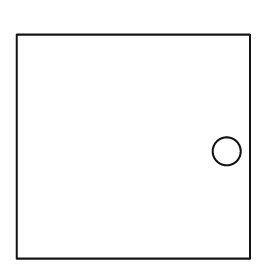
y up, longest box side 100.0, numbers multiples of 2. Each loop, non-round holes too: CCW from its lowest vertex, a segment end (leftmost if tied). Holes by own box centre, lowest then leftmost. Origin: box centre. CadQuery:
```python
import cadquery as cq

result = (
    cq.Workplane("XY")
    .moveTo(-50.0, -48.0)
    .lineTo(50.0, -48.0)
    .lineTo(50.0, 48.0)
    .lineTo(-50.0, 48.0)
    .close()
    .moveTo(40.0, -2.0)
    .circle(6.0)
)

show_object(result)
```